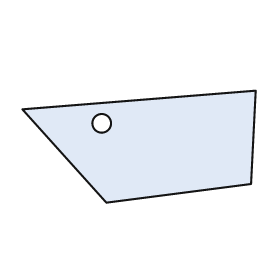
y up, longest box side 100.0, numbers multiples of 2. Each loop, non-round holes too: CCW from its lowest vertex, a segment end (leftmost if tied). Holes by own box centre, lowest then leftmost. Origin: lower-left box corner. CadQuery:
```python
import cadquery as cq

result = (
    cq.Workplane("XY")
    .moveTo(36.0, 0.0)
    .lineTo(98.0, 8.0)
    .lineTo(100.0, 48.0)
    .lineTo(0.0, 40.0)
    .close()
    .moveTo(34.0, 34.0)
    .circle(4.0)
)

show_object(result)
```